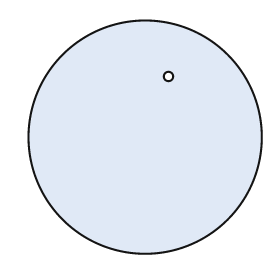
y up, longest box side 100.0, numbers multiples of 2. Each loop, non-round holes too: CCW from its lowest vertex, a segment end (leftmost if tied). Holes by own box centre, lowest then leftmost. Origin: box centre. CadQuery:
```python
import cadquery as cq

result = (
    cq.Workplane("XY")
    .moveTo(0.0, 0.0)
    .circle(50.0)
    .moveTo(10.0, 26.0)
    .circle(2.0)
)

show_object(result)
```